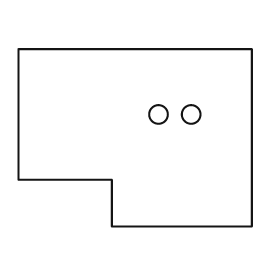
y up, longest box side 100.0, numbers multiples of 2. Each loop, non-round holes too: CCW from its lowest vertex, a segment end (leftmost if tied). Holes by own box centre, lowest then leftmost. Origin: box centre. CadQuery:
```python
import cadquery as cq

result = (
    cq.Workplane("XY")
    .moveTo(-10.0, -38.0)
    .lineTo(50.0, -38.0)
    .lineTo(50.0, 38.0)
    .lineTo(-50.0, 38.0)
    .lineTo(-50.0, -18.0)
    .lineTo(-10.0, -18.0)
    .close()
    .moveTo(10.0, 10.0)
    .circle(4.0)
    .moveTo(24.0, 10.0)
    .circle(4.0)
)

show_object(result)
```